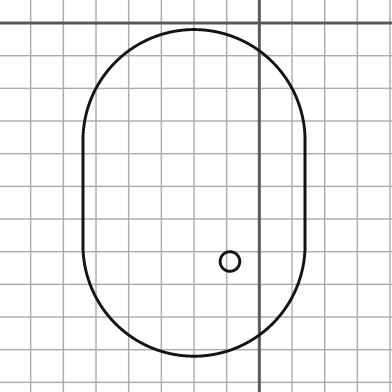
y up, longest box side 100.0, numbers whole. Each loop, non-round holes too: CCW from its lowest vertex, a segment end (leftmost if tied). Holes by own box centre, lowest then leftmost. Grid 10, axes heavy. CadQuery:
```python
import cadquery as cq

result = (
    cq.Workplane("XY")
    .moveTo(-54.0, -68.0)
    .threePointArc((-20.0, -102.0), (14.0, -68.0))
    .lineTo(14.0, -36.0)
    .threePointArc((-20.0, -2.0), (-54.0, -36.0))
    .close()
    .moveTo(-9.0, -73.0)
    .circle(3.0)
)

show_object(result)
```